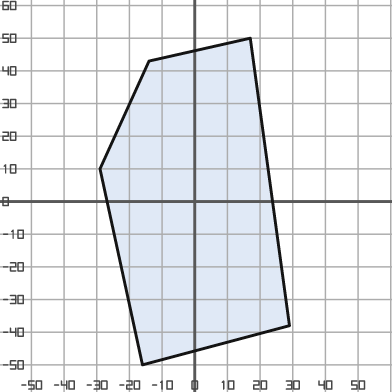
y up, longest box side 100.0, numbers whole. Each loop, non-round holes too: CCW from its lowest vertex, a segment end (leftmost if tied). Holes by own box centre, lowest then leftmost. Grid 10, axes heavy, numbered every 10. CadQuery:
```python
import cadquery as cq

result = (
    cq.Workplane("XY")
    .moveTo(-16.0, -50.0)
    .lineTo(29.0, -38.0)
    .lineTo(17.0, 50.0)
    .lineTo(-14.0, 43.0)
    .lineTo(-29.0, 10.0)
    .close()
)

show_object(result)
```